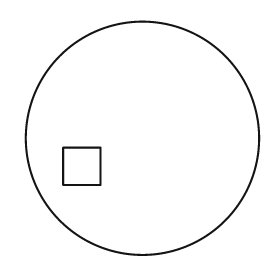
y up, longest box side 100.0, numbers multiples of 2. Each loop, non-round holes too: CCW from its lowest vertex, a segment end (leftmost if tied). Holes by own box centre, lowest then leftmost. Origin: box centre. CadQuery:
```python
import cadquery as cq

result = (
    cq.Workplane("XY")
    .moveTo(0.0, 0.0)
    .circle(50.0)
    .moveTo(-34.0, -20.0)
    .lineTo(-18.0, -20.0)
    .lineTo(-18.0, -4.0)
    .lineTo(-34.0, -4.0)
    .close()
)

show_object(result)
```